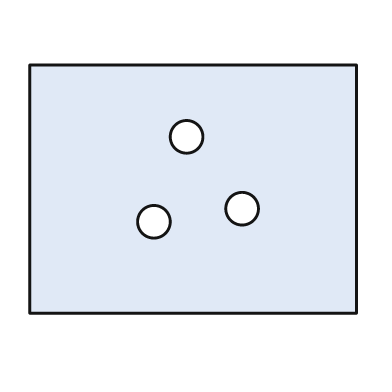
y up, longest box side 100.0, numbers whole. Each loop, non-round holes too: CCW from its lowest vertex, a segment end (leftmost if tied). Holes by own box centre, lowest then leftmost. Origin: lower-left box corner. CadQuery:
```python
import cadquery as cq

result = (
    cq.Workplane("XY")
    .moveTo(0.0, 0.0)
    .lineTo(100.0, 0.0)
    .lineTo(100.0, 76.0)
    .lineTo(0.0, 76.0)
    .close()
    .moveTo(38.0, 28.0)
    .circle(5.0)
    .moveTo(65.0, 32.0)
    .circle(5.0)
    .moveTo(48.0, 54.0)
    .circle(5.0)
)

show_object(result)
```